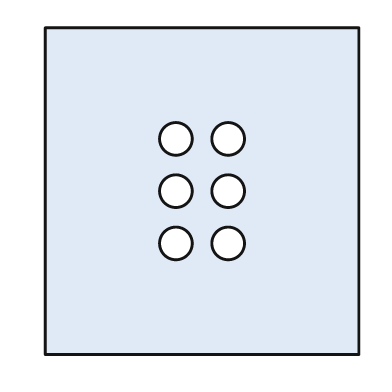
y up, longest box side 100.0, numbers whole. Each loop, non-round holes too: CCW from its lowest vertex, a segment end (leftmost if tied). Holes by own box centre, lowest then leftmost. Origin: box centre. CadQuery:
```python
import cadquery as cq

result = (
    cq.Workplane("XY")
    .moveTo(-48.0, -50.0)
    .lineTo(48.0, -50.0)
    .lineTo(48.0, 50.0)
    .lineTo(-48.0, 50.0)
    .close()
    .moveTo(-8.0, -16.0)
    .circle(5.0)
    .moveTo(8.0, -16.0)
    .circle(5.0)
    .moveTo(-8.0, 0.0)
    .circle(5.0)
    .moveTo(8.0, 0.0)
    .circle(5.0)
    .moveTo(-8.0, 16.0)
    .circle(5.0)
    .moveTo(8.0, 16.0)
    .circle(5.0)
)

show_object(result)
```